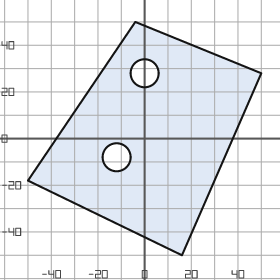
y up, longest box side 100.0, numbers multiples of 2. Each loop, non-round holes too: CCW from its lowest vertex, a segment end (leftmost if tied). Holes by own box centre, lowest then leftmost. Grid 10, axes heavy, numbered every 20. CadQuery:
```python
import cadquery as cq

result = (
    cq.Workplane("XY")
    .moveTo(16.0, -50.0)
    .lineTo(50.0, 28.0)
    .lineTo(-4.0, 50.0)
    .lineTo(-50.0, -18.0)
    .close()
    .moveTo(-12.0, -8.0)
    .circle(6.0)
    .moveTo(0.0, 28.0)
    .circle(6.0)
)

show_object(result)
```